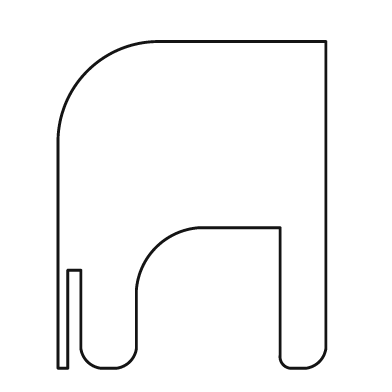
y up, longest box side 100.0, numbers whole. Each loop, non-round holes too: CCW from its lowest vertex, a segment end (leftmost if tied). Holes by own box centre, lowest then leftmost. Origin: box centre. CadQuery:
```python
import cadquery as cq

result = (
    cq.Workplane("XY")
    .moveTo(-41.0, -50.0)
    .lineTo(-38.0, -50.0)
    .lineTo(-38.0, -20.0)
    .lineTo(-34.0, -20.0)
    .lineTo(-34.0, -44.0)
    .threePointArc((-32.0, -48.0), (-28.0, -50.0))
    .lineTo(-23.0, -50.0)
    .threePointArc((-19.0, -48.0), (-17.0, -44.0))
    .lineTo(-17.0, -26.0)
    .threePointArc((-11.0, -13.0), (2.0, -7.0))
    .lineTo(27.0, -7.0)
    .lineTo(27.0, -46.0)
    .threePointArc((28.0, -49.0), (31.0, -50.0))
    .lineTo(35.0, -50.0)
    .threePointArc((39.0, -48.0), (41.0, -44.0))
    .lineTo(41.0, 50.0)
    .lineTo(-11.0, 50.0)
    .threePointArc((-32.0, 41.0), (-41.0, 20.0))
    .close()
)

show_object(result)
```